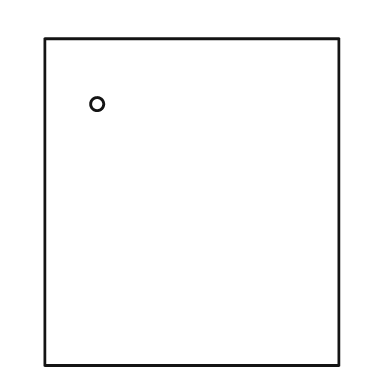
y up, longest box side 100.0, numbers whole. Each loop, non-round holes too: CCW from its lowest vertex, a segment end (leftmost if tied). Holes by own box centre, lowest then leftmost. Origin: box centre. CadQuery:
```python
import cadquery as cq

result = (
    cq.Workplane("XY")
    .moveTo(-45.0, -50.0)
    .lineTo(45.0, -50.0)
    .lineTo(45.0, 50.0)
    .lineTo(-45.0, 50.0)
    .close()
    .moveTo(-29.0, 30.0)
    .circle(2.0)
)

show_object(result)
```